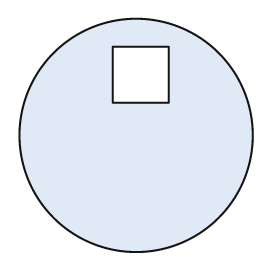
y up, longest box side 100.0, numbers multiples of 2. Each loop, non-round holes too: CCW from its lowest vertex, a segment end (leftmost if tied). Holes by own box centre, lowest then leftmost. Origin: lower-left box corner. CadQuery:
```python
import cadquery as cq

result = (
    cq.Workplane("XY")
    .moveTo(50.0, 50.0)
    .circle(50.0)
    .moveTo(40.0, 64.0)
    .lineTo(64.0, 64.0)
    .lineTo(64.0, 88.0)
    .lineTo(40.0, 88.0)
    .close()
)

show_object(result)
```